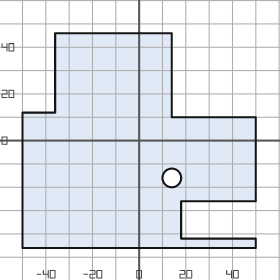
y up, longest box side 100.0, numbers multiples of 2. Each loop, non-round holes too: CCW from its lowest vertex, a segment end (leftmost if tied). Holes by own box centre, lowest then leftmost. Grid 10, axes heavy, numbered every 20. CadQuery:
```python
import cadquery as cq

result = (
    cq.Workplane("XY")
    .moveTo(-50.0, -46.0)
    .lineTo(50.0, -46.0)
    .lineTo(50.0, -42.0)
    .lineTo(18.0, -42.0)
    .lineTo(18.0, -26.0)
    .lineTo(50.0, -26.0)
    .lineTo(50.0, 10.0)
    .lineTo(14.0, 10.0)
    .lineTo(14.0, 46.0)
    .lineTo(-36.0, 46.0)
    .lineTo(-36.0, 12.0)
    .lineTo(-50.0, 12.0)
    .close()
    .moveTo(14.0, -16.0)
    .circle(4.0)
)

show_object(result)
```